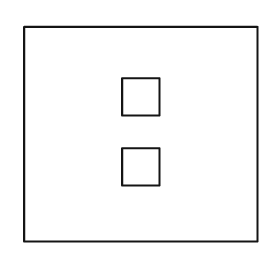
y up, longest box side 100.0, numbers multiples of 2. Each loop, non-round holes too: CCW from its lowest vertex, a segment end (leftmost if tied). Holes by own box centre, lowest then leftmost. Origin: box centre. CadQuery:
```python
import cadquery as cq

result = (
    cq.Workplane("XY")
    .moveTo(-50.0, -46.0)
    .lineTo(50.0, -46.0)
    .lineTo(50.0, 46.0)
    .lineTo(-50.0, 46.0)
    .close()
    .moveTo(-8.0, -22.0)
    .lineTo(8.0, -22.0)
    .lineTo(8.0, -6.0)
    .lineTo(-8.0, -6.0)
    .close()
    .moveTo(-8.0, 8.0)
    .lineTo(8.0, 8.0)
    .lineTo(8.0, 24.0)
    .lineTo(-8.0, 24.0)
    .close()
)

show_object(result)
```